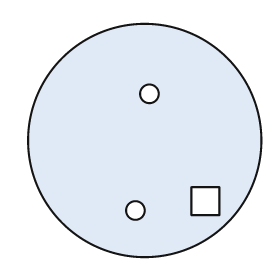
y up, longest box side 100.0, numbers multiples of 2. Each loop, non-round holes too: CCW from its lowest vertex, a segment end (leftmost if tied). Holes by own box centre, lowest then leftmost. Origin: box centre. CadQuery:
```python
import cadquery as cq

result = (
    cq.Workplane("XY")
    .moveTo(0.0, 0.0)
    .circle(50.0)
    .moveTo(-4.0, -30.0)
    .circle(4.0)
    .moveTo(20.0, -32.0)
    .lineTo(32.0, -32.0)
    .lineTo(32.0, -20.0)
    .lineTo(20.0, -20.0)
    .close()
    .moveTo(2.0, 20.0)
    .circle(4.0)
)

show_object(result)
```